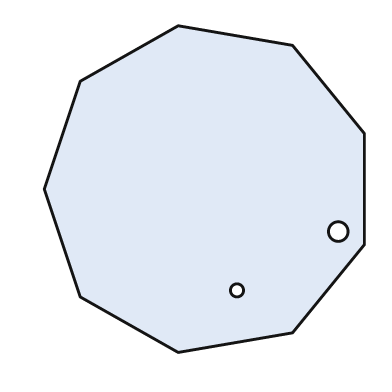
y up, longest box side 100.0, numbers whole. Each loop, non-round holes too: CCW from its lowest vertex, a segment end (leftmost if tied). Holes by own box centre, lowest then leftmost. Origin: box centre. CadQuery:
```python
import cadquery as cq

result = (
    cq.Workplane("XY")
    .moveTo(-8.0, -50.0)
    .lineTo(27.0, -44.0)
    .lineTo(49.0, -17.0)
    .lineTo(49.0, 17.0)
    .lineTo(27.0, 44.0)
    .lineTo(-8.0, 50.0)
    .lineTo(-38.0, 33.0)
    .lineTo(-49.0, 0.0)
    .lineTo(-38.0, -33.0)
    .close()
    .moveTo(10.0, -31.0)
    .circle(2.0)
    .moveTo(41.0, -13.0)
    .circle(3.0)
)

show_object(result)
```